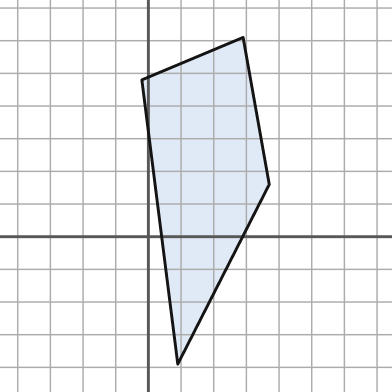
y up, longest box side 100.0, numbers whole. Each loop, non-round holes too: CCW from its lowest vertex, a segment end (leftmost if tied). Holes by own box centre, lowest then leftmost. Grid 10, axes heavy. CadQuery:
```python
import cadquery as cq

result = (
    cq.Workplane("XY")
    .moveTo(9.0, -39.0)
    .lineTo(37.0, 16.0)
    .lineTo(29.0, 61.0)
    .lineTo(-2.0, 48.0)
    .close()
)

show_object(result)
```